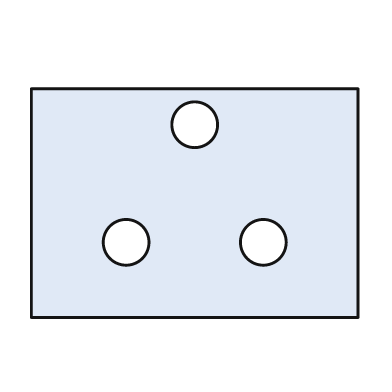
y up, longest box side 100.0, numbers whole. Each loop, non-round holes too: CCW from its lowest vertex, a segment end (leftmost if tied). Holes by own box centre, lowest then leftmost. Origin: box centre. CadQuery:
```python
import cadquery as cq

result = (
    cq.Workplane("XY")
    .moveTo(-50.0, -35.0)
    .lineTo(50.0, -35.0)
    .lineTo(50.0, 35.0)
    .lineTo(-50.0, 35.0)
    .close()
    .moveTo(-21.0, -12.0)
    .circle(7.0)
    .moveTo(21.0, -12.0)
    .circle(7.0)
    .moveTo(0.0, 24.0)
    .circle(7.0)
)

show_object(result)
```